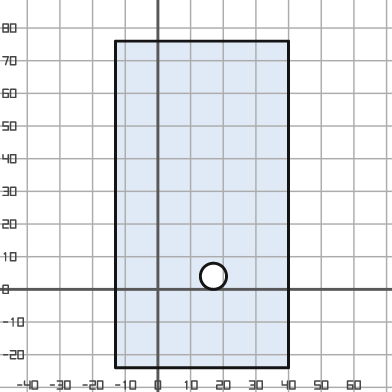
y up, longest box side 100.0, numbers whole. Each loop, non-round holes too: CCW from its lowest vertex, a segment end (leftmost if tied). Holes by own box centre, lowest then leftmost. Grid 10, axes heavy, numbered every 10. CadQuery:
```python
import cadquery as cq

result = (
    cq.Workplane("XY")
    .moveTo(-13.0, -24.0)
    .lineTo(40.0, -24.0)
    .lineTo(40.0, 76.0)
    .lineTo(-13.0, 76.0)
    .close()
    .moveTo(17.0, 4.0)
    .circle(4.0)
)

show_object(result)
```